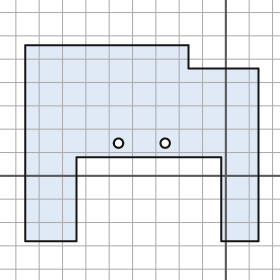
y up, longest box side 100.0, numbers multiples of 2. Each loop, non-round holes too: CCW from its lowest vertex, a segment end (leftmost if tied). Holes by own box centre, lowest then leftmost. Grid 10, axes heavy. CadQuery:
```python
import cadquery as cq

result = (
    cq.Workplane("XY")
    .moveTo(-86.0, -28.0)
    .lineTo(-64.0, -28.0)
    .lineTo(-64.0, 8.0)
    .lineTo(-2.0, 8.0)
    .lineTo(-2.0, -28.0)
    .lineTo(14.0, -28.0)
    .lineTo(14.0, 46.0)
    .lineTo(-16.0, 46.0)
    .lineTo(-16.0, 56.0)
    .lineTo(-86.0, 56.0)
    .close()
    .moveTo(-46.0, 14.0)
    .circle(2.0)
    .moveTo(-26.0, 14.0)
    .circle(2.0)
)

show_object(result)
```